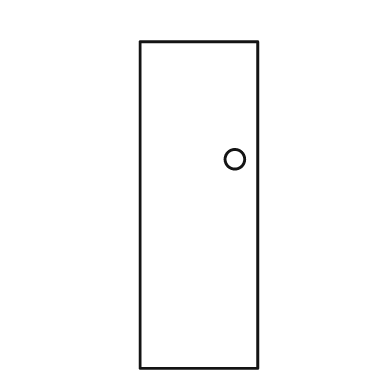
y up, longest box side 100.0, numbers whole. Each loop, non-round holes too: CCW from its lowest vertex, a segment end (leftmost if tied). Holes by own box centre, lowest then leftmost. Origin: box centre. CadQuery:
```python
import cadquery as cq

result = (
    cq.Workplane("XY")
    .moveTo(-18.0, -50.0)
    .lineTo(18.0, -50.0)
    .lineTo(18.0, 50.0)
    .lineTo(-18.0, 50.0)
    .close()
    .moveTo(11.0, 14.0)
    .circle(3.0)
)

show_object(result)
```